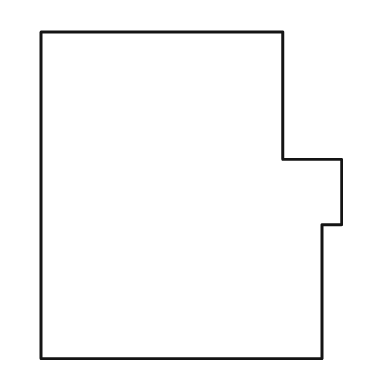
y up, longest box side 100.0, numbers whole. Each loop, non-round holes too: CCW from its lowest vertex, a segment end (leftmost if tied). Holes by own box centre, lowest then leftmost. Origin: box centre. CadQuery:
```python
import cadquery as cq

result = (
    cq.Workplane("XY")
    .moveTo(-46.0, -50.0)
    .lineTo(40.0, -50.0)
    .lineTo(40.0, -9.0)
    .lineTo(46.0, -9.0)
    .lineTo(46.0, 11.0)
    .lineTo(28.0, 11.0)
    .lineTo(28.0, 50.0)
    .lineTo(-46.0, 50.0)
    .close()
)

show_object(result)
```